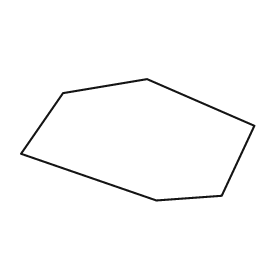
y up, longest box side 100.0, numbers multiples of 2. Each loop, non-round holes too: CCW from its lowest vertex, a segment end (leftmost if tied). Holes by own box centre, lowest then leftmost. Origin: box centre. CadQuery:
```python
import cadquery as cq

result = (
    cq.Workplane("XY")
    .moveTo(8.0, -26.0)
    .lineTo(36.0, -24.0)
    .lineTo(50.0, 6.0)
    .lineTo(4.0, 26.0)
    .lineTo(-32.0, 20.0)
    .lineTo(-50.0, -6.0)
    .close()
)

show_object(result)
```